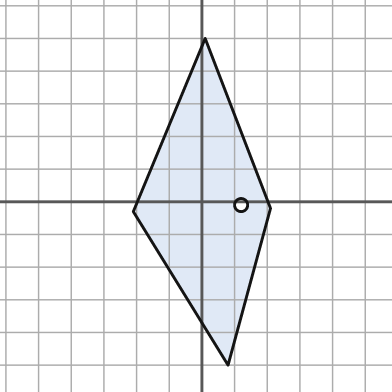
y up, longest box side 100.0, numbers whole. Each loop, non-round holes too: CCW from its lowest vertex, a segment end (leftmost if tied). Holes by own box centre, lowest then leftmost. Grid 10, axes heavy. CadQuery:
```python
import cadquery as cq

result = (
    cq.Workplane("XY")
    .moveTo(8.0, -50.0)
    .lineTo(21.0, -2.0)
    .lineTo(1.0, 50.0)
    .lineTo(-21.0, -3.0)
    .close()
    .moveTo(12.0, -1.0)
    .circle(2.0)
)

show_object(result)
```